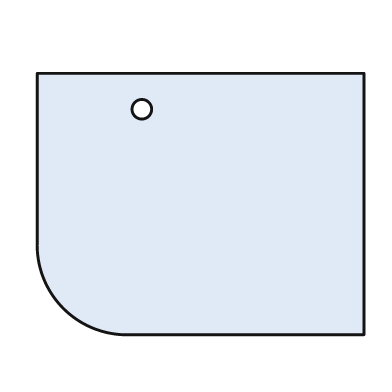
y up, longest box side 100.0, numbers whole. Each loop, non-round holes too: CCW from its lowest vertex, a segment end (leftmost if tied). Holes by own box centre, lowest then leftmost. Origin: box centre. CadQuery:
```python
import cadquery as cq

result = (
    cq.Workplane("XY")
    .moveTo(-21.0, -40.0)
    .lineTo(50.0, -40.0)
    .lineTo(50.0, 40.0)
    .lineTo(-50.0, 40.0)
    .lineTo(-50.0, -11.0)
    .threePointArc((-42.0, -32.0), (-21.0, -40.0))
    .close()
    .moveTo(-18.0, 29.0)
    .circle(3.0)
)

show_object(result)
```